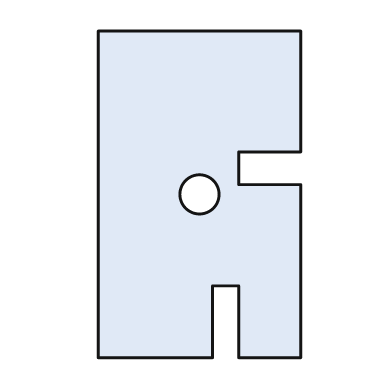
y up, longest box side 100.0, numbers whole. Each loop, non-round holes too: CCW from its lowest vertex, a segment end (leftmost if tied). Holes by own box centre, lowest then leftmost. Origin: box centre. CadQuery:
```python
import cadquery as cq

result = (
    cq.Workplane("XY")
    .moveTo(-31.0, -50.0)
    .lineTo(4.0, -50.0)
    .lineTo(4.0, -28.0)
    .lineTo(12.0, -28.0)
    .lineTo(12.0, -50.0)
    .lineTo(31.0, -50.0)
    .lineTo(31.0, 3.0)
    .lineTo(12.0, 3.0)
    .lineTo(12.0, 13.0)
    .lineTo(31.0, 13.0)
    .lineTo(31.0, 50.0)
    .lineTo(-31.0, 50.0)
    .close()
    .moveTo(0.0, 0.0)
    .circle(6.0)
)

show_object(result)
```